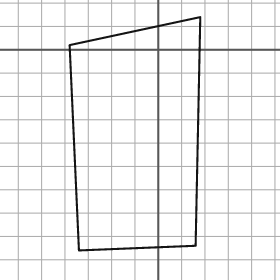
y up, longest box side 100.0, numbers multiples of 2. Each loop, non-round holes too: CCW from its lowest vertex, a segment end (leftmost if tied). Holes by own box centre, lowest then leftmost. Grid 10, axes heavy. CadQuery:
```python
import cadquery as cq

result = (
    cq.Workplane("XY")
    .moveTo(-34.0, -86.0)
    .lineTo(16.0, -84.0)
    .lineTo(18.0, 14.0)
    .lineTo(-38.0, 2.0)
    .close()
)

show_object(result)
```